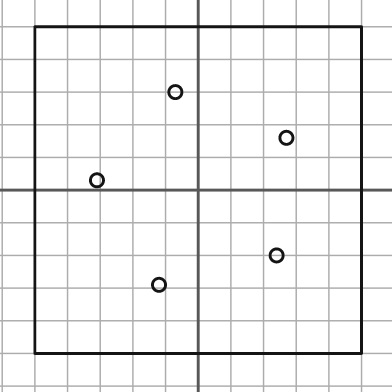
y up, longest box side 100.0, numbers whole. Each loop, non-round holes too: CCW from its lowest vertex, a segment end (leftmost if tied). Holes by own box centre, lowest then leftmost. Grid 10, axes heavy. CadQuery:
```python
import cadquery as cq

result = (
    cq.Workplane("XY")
    .moveTo(-50.0, -50.0)
    .lineTo(50.0, -50.0)
    .lineTo(50.0, 50.0)
    .lineTo(-50.0, 50.0)
    .close()
    .moveTo(-12.0, -29.0)
    .circle(2.0)
    .moveTo(24.0, -20.0)
    .circle(2.0)
    .moveTo(-31.0, 3.0)
    .circle(2.0)
    .moveTo(27.0, 16.0)
    .circle(2.0)
    .moveTo(-7.0, 30.0)
    .circle(2.0)
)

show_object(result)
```